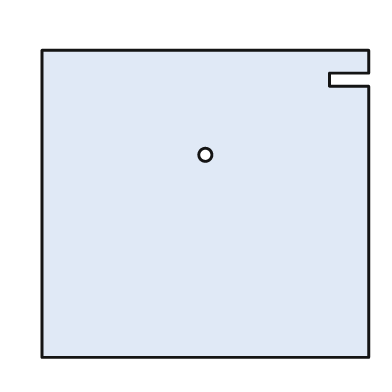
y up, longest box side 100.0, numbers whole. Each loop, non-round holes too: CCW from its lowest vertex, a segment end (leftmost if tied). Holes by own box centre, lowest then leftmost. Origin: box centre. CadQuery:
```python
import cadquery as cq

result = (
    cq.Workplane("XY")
    .moveTo(-50.0, -47.0)
    .lineTo(50.0, -47.0)
    .lineTo(50.0, 36.0)
    .lineTo(38.0, 36.0)
    .lineTo(38.0, 40.0)
    .lineTo(50.0, 40.0)
    .lineTo(50.0, 47.0)
    .lineTo(-50.0, 47.0)
    .close()
    .moveTo(0.0, 15.0)
    .circle(2.0)
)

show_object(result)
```